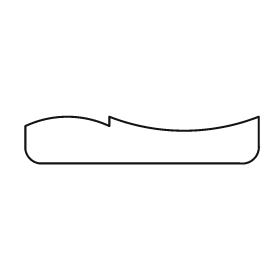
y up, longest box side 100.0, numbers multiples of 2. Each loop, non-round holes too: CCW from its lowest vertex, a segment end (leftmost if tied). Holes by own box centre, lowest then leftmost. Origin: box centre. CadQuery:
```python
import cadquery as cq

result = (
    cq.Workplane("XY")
    .moveTo(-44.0, -10.0)
    .lineTo(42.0, -10.0)
    .threePointArc((48.0, -8.0), (50.0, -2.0))
    .lineTo(50.0, 10.0)
    .threePointArc((18.0, 4.0), (-14.0, 10.0))
    .lineTo(-14.0, 6.0)
    .threePointArc((-32.0, 10.0), (-50.0, 6.0))
    .lineTo(-50.0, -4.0)
    .threePointArc((-48.0, -8.0), (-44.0, -10.0))
    .close()
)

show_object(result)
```